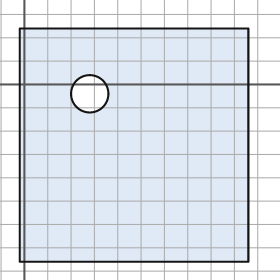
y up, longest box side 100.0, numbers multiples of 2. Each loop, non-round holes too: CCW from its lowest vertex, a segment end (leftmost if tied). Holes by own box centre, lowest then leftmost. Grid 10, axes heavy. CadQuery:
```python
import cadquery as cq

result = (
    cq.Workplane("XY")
    .moveTo(-2.0, -76.0)
    .lineTo(96.0, -76.0)
    .lineTo(96.0, 24.0)
    .lineTo(-2.0, 24.0)
    .close()
    .moveTo(28.0, -4.0)
    .circle(8.0)
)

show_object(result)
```